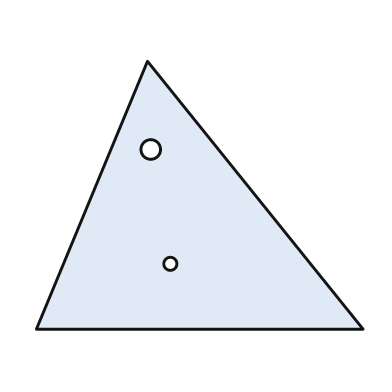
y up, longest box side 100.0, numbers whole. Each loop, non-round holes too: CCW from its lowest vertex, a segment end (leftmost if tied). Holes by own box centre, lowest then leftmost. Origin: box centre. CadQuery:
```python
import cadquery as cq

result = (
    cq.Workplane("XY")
    .moveTo(-50.0, -41.0)
    .lineTo(50.0, -41.0)
    .lineTo(-16.0, 41.0)
    .close()
    .moveTo(-9.0, -21.0)
    .circle(2.0)
    .moveTo(-15.0, 14.0)
    .circle(3.0)
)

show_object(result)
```